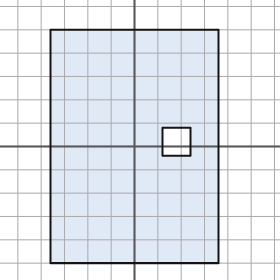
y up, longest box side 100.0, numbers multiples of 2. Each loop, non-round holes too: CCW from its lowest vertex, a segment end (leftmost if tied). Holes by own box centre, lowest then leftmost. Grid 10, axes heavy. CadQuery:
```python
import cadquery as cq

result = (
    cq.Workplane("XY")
    .moveTo(-36.0, -50.0)
    .lineTo(36.0, -50.0)
    .lineTo(36.0, 50.0)
    .lineTo(-36.0, 50.0)
    .close()
    .moveTo(12.0, -4.0)
    .lineTo(24.0, -4.0)
    .lineTo(24.0, 8.0)
    .lineTo(12.0, 8.0)
    .close()
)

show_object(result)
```